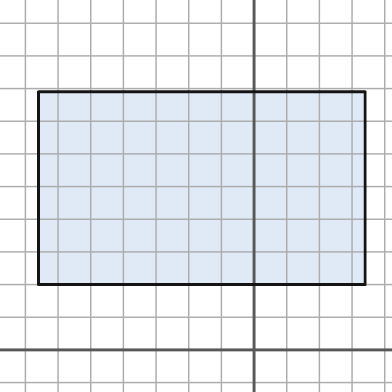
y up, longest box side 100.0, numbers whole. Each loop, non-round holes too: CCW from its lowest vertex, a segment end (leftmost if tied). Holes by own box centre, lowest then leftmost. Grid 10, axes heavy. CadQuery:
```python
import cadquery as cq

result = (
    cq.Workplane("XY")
    .moveTo(-66.0, 20.0)
    .lineTo(34.0, 20.0)
    .lineTo(34.0, 79.0)
    .lineTo(-66.0, 79.0)
    .close()
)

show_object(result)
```